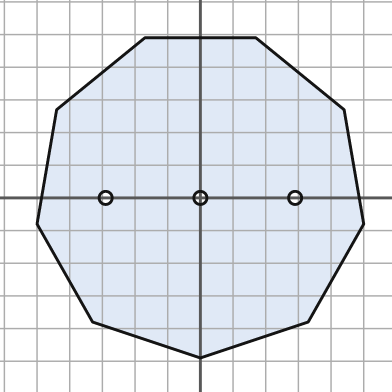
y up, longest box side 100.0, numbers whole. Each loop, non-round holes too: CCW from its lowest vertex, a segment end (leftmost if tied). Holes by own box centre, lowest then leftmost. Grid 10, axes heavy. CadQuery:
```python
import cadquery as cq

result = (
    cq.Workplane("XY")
    .moveTo(0.0, -49.0)
    .lineTo(33.0, -38.0)
    .lineTo(50.0, -8.0)
    .lineTo(44.0, 27.0)
    .lineTo(17.0, 49.0)
    .lineTo(-17.0, 49.0)
    .lineTo(-44.0, 27.0)
    .lineTo(-50.0, -8.0)
    .lineTo(-33.0, -38.0)
    .close()
    .moveTo(-29.0, 0.0)
    .circle(2.0)
    .moveTo(0.0, 0.0)
    .circle(2.0)
    .moveTo(29.0, 0.0)
    .circle(2.0)
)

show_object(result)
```